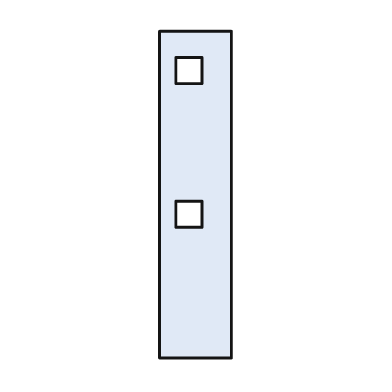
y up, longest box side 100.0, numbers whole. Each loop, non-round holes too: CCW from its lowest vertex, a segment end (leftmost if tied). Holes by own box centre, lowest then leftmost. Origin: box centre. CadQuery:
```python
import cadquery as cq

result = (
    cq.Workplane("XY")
    .moveTo(-11.0, -50.0)
    .lineTo(11.0, -50.0)
    .lineTo(11.0, 50.0)
    .lineTo(-11.0, 50.0)
    .close()
    .moveTo(-6.0, -10.0)
    .lineTo(2.0, -10.0)
    .lineTo(2.0, -2.0)
    .lineTo(-6.0, -2.0)
    .close()
    .moveTo(-6.0, 34.0)
    .lineTo(2.0, 34.0)
    .lineTo(2.0, 42.0)
    .lineTo(-6.0, 42.0)
    .close()
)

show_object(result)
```